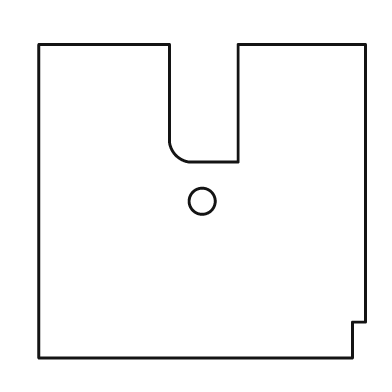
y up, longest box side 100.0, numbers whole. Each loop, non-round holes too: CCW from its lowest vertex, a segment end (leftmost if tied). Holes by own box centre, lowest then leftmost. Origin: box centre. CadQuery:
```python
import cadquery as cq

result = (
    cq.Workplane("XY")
    .moveTo(-50.0, -48.0)
    .lineTo(46.0, -48.0)
    .lineTo(46.0, -37.0)
    .lineTo(50.0, -37.0)
    .lineTo(50.0, 48.0)
    .lineTo(11.0, 48.0)
    .lineTo(11.0, 12.0)
    .lineTo(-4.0, 12.0)
    .threePointArc((-8.0, 14.0), (-10.0, 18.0))
    .lineTo(-10.0, 48.0)
    .lineTo(-50.0, 48.0)
    .close()
    .moveTo(0.0, 0.0)
    .circle(4.0)
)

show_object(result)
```